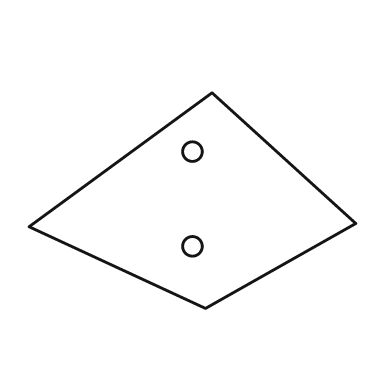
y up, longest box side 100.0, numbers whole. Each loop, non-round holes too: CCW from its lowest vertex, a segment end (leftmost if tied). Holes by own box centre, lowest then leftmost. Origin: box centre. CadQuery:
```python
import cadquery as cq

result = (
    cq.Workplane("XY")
    .moveTo(4.0, -33.0)
    .lineTo(50.0, -7.0)
    .lineTo(6.0, 33.0)
    .lineTo(-50.0, -8.0)
    .close()
    .moveTo(0.0, -14.0)
    .circle(3.0)
    .moveTo(0.0, 15.0)
    .circle(3.0)
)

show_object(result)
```